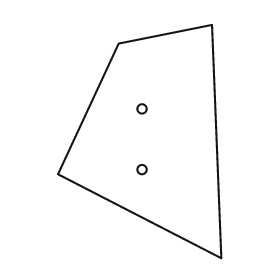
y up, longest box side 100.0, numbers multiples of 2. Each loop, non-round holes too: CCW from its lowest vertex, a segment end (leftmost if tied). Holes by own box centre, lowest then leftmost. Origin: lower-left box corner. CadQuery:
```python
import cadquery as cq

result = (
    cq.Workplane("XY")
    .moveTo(70.0, 0.0)
    .lineTo(66.0, 100.0)
    .lineTo(26.0, 92.0)
    .lineTo(0.0, 36.0)
    .close()
    .moveTo(36.0, 38.0)
    .circle(2.0)
    .moveTo(36.0, 64.0)
    .circle(2.0)
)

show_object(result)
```